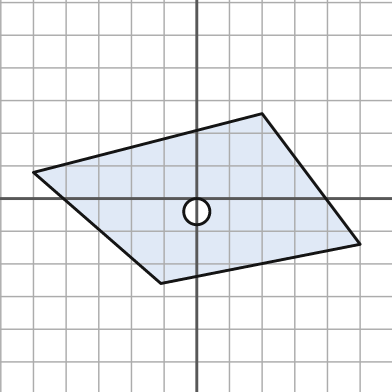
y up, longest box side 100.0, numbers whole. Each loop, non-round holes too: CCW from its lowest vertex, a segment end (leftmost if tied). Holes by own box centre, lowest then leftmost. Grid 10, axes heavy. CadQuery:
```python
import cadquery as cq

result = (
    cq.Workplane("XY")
    .moveTo(-11.0, -26.0)
    .lineTo(50.0, -14.0)
    .lineTo(20.0, 26.0)
    .lineTo(-50.0, 8.0)
    .close()
    .moveTo(0.0, -4.0)
    .circle(4.0)
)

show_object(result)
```